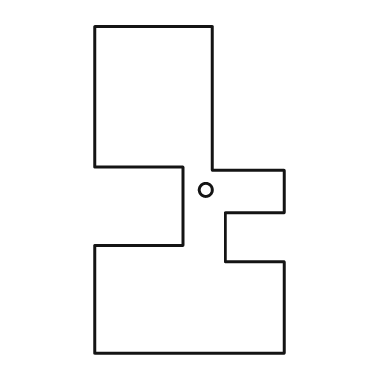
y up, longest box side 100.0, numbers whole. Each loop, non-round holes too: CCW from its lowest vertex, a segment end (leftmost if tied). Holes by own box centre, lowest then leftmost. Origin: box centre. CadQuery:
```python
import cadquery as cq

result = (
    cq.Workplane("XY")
    .moveTo(-29.0, -50.0)
    .lineTo(29.0, -50.0)
    .lineTo(29.0, -22.0)
    .lineTo(11.0, -22.0)
    .lineTo(11.0, -7.0)
    .lineTo(29.0, -7.0)
    .lineTo(29.0, 6.0)
    .lineTo(7.0, 6.0)
    .lineTo(7.0, 50.0)
    .lineTo(-29.0, 50.0)
    .lineTo(-29.0, 7.0)
    .lineTo(-2.0, 7.0)
    .lineTo(-2.0, -17.0)
    .lineTo(-29.0, -17.0)
    .close()
    .moveTo(5.0, 0.0)
    .circle(2.0)
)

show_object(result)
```